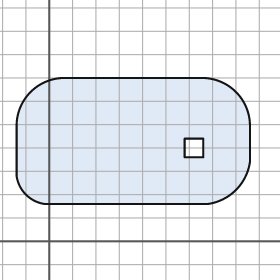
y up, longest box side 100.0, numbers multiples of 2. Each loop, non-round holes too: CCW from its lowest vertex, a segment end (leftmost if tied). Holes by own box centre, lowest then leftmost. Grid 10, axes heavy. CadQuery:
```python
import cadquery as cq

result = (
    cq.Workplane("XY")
    .moveTo(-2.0, 16.0)
    .lineTo(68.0, 16.0)
    .threePointArc((80.0, 22.0), (86.0, 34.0))
    .lineTo(86.0, 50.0)
    .threePointArc((80.0, 64.0), (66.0, 70.0))
    .lineTo(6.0, 70.0)
    .threePointArc((-8.0, 64.0), (-14.0, 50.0))
    .lineTo(-14.0, 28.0)
    .threePointArc((-10.0, 20.0), (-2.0, 16.0))
    .close()
    .moveTo(58.0, 36.0)
    .lineTo(66.0, 36.0)
    .lineTo(66.0, 44.0)
    .lineTo(58.0, 44.0)
    .close()
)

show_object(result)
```